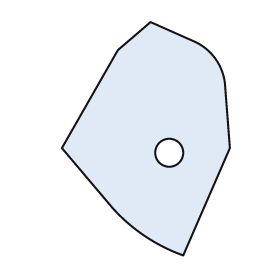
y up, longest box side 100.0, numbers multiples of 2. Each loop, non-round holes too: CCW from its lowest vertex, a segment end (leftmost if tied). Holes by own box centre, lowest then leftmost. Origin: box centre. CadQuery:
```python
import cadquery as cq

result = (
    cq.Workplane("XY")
    .moveTo(16.0, -50.0)
    .lineTo(36.0, -4.0)
    .lineTo(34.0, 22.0)
    .threePointArc((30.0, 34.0), (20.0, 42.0))
    .lineTo(2.0, 50.0)
    .lineTo(-12.0, 38.0)
    .lineTo(-36.0, -4.0)
    .lineTo(-14.0, -30.0)
    .threePointArc((0.0, -42.0), (16.0, -50.0))
    .close()
    .moveTo(10.0, -6.0)
    .circle(6.0)
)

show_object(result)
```